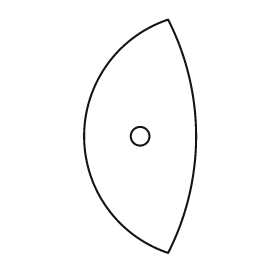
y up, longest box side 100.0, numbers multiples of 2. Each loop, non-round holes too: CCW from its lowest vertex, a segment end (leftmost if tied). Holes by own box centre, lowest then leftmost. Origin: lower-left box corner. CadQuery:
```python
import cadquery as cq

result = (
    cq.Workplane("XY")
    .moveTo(36.0, 0.0)
    .threePointArc((48.0, 50.0), (36.0, 100.0))
    .threePointArc((0.0, 50.0), (36.0, 0.0))
    .close()
    .moveTo(24.0, 50.0)
    .circle(4.0)
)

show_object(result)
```